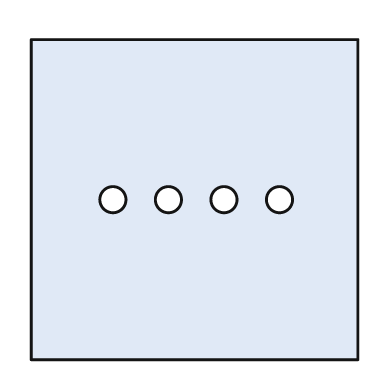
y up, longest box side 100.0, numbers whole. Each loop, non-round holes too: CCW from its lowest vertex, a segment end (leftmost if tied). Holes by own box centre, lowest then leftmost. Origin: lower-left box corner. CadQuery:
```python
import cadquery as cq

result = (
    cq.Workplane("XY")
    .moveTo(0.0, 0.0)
    .lineTo(100.0, 0.0)
    .lineTo(100.0, 98.0)
    .lineTo(0.0, 98.0)
    .close()
    .moveTo(25.0, 49.0)
    .circle(4.0)
    .moveTo(42.0, 49.0)
    .circle(4.0)
    .moveTo(59.0, 49.0)
    .circle(4.0)
    .moveTo(76.0, 49.0)
    .circle(4.0)
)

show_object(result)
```